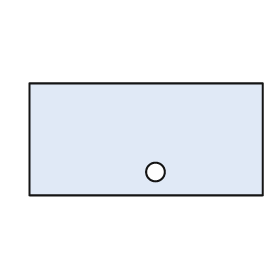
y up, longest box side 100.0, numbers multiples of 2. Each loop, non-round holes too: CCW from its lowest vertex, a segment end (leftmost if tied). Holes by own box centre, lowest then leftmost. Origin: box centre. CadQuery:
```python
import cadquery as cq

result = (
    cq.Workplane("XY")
    .moveTo(-50.0, -24.0)
    .lineTo(50.0, -24.0)
    .lineTo(50.0, 24.0)
    .lineTo(-50.0, 24.0)
    .close()
    .moveTo(4.0, -14.0)
    .circle(4.0)
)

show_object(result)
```